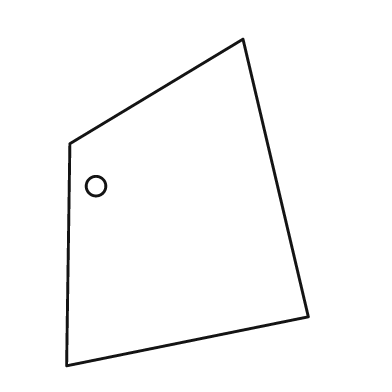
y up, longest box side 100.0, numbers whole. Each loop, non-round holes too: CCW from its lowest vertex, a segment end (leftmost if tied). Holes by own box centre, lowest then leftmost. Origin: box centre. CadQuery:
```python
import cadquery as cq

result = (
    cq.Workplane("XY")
    .moveTo(-37.0, -50.0)
    .lineTo(37.0, -35.0)
    .lineTo(17.0, 50.0)
    .lineTo(-36.0, 18.0)
    .close()
    .moveTo(-28.0, 5.0)
    .circle(3.0)
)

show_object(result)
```